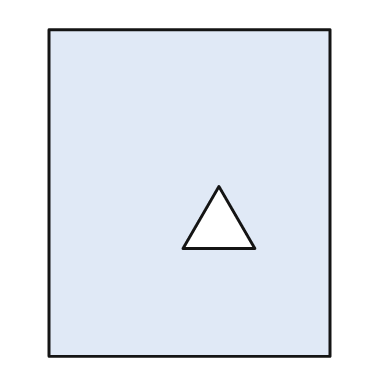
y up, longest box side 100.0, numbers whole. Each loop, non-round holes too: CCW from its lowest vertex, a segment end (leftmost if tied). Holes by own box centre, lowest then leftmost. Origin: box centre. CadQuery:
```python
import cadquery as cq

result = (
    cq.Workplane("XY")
    .moveTo(-43.0, -50.0)
    .lineTo(43.0, -50.0)
    .lineTo(43.0, 50.0)
    .lineTo(-43.0, 50.0)
    .close()
    .moveTo(-2.0, -17.0)
    .lineTo(20.0, -17.0)
    .lineTo(9.0, 2.0)
    .close()
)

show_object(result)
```